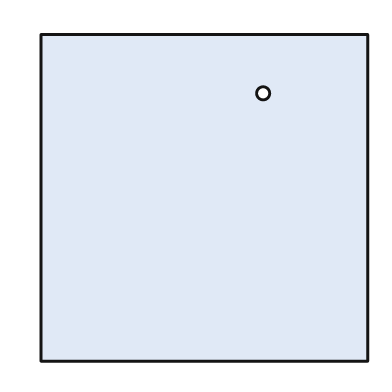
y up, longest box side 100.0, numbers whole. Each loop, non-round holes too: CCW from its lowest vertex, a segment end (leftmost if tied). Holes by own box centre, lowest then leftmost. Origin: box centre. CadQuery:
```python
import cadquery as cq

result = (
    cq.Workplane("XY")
    .moveTo(-50.0, -50.0)
    .lineTo(50.0, -50.0)
    .lineTo(50.0, 50.0)
    .lineTo(-50.0, 50.0)
    .close()
    .moveTo(18.0, 32.0)
    .circle(2.0)
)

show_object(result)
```